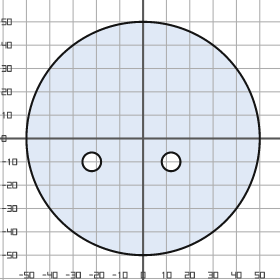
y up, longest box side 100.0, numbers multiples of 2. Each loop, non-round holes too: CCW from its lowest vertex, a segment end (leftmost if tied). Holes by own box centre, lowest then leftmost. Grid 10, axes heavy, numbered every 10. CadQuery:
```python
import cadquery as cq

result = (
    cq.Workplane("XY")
    .moveTo(0.0, 0.0)
    .circle(50.0)
    .moveTo(-22.0, -10.0)
    .circle(4.0)
    .moveTo(12.0, -10.0)
    .circle(4.0)
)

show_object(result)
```